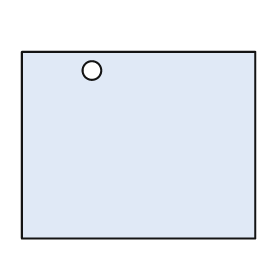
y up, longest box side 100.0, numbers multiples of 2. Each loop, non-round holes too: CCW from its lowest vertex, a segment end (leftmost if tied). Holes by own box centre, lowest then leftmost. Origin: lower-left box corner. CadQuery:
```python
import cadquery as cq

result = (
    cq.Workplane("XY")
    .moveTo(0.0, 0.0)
    .lineTo(100.0, 0.0)
    .lineTo(100.0, 80.0)
    .lineTo(0.0, 80.0)
    .close()
    .moveTo(30.0, 72.0)
    .circle(4.0)
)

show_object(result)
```